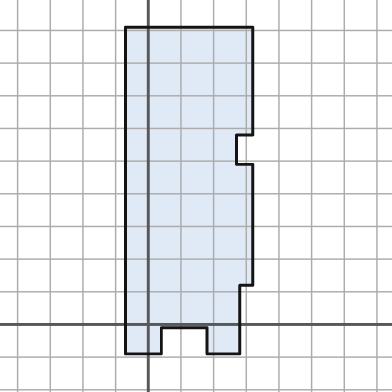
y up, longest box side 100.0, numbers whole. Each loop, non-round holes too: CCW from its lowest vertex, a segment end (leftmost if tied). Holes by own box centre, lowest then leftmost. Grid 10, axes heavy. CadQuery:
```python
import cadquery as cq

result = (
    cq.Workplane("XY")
    .moveTo(-7.0, -9.0)
    .lineTo(4.0, -9.0)
    .lineTo(4.0, -1.0)
    .lineTo(18.0, -1.0)
    .lineTo(18.0, -9.0)
    .lineTo(28.0, -9.0)
    .lineTo(28.0, 12.0)
    .lineTo(32.0, 12.0)
    .lineTo(32.0, 49.0)
    .lineTo(27.0, 49.0)
    .lineTo(27.0, 58.0)
    .lineTo(32.0, 58.0)
    .lineTo(32.0, 91.0)
    .lineTo(-7.0, 91.0)
    .close()
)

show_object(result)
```